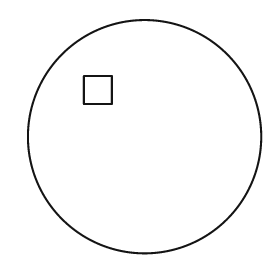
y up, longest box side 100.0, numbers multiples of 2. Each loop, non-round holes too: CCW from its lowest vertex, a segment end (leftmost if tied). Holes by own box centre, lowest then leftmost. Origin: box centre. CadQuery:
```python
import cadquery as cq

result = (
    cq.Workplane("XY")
    .moveTo(0.0, 0.0)
    .circle(50.0)
    .moveTo(-26.0, 14.0)
    .lineTo(-14.0, 14.0)
    .lineTo(-14.0, 26.0)
    .lineTo(-26.0, 26.0)
    .close()
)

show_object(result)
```